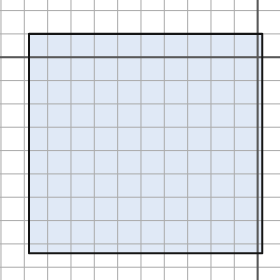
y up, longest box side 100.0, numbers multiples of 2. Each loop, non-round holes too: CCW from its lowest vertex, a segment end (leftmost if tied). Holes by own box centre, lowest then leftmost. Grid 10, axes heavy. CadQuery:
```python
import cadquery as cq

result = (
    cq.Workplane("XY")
    .moveTo(-98.0, -84.0)
    .lineTo(2.0, -84.0)
    .lineTo(2.0, 10.0)
    .lineTo(-98.0, 10.0)
    .close()
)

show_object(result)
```